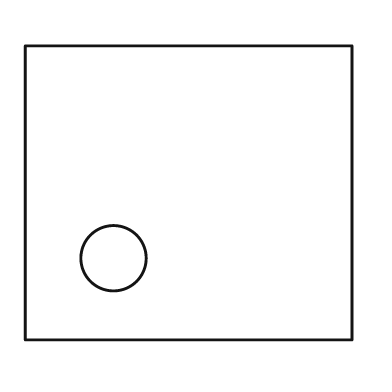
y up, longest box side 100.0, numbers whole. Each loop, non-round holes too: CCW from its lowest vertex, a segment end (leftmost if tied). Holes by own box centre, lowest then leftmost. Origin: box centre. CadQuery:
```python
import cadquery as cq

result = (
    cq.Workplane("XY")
    .moveTo(-50.0, -45.0)
    .lineTo(50.0, -45.0)
    .lineTo(50.0, 45.0)
    .lineTo(-50.0, 45.0)
    .close()
    .moveTo(-23.0, -20.0)
    .circle(10.0)
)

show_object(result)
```